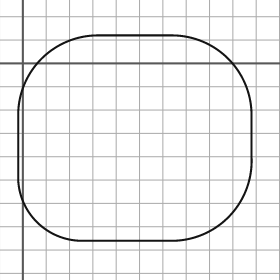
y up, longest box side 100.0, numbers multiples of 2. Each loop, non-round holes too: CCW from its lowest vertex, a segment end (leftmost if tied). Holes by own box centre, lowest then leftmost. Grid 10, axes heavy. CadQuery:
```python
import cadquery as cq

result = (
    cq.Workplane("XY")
    .moveTo(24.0, -76.0)
    .lineTo(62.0, -76.0)
    .threePointArc((88.0, -66.0), (98.0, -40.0))
    .lineTo(98.0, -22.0)
    .threePointArc((88.0, 2.0), (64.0, 12.0))
    .lineTo(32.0, 12.0)
    .threePointArc((8.0, 2.0), (-2.0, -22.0))
    .lineTo(-2.0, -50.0)
    .threePointArc((6.0, -68.0), (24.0, -76.0))
    .close()
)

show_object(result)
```